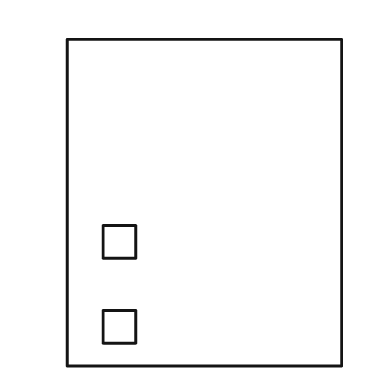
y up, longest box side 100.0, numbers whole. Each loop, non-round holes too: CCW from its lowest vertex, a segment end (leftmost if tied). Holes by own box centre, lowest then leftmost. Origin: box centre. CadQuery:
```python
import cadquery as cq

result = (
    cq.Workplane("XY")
    .moveTo(-42.0, -50.0)
    .lineTo(42.0, -50.0)
    .lineTo(42.0, 50.0)
    .lineTo(-42.0, 50.0)
    .close()
    .moveTo(-31.0, -43.0)
    .lineTo(-21.0, -43.0)
    .lineTo(-21.0, -33.0)
    .lineTo(-31.0, -33.0)
    .close()
    .moveTo(-31.0, -17.0)
    .lineTo(-21.0, -17.0)
    .lineTo(-21.0, -7.0)
    .lineTo(-31.0, -7.0)
    .close()
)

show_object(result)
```